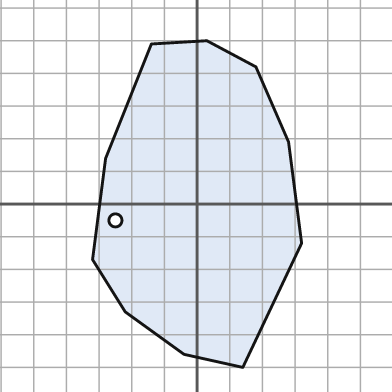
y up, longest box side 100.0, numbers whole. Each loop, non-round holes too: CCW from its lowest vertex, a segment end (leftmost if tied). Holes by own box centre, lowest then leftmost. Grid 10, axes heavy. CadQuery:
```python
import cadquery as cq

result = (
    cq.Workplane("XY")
    .moveTo(14.0, -50.0)
    .lineTo(32.0, -12.0)
    .lineTo(28.0, 19.0)
    .lineTo(18.0, 42.0)
    .lineTo(3.0, 50.0)
    .lineTo(-14.0, 49.0)
    .lineTo(-28.0, 14.0)
    .lineTo(-32.0, -17.0)
    .lineTo(-22.0, -33.0)
    .lineTo(-4.0, -46.0)
    .close()
    .moveTo(-25.0, -5.0)
    .circle(2.0)
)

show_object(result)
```